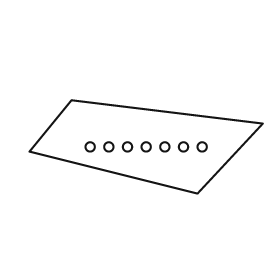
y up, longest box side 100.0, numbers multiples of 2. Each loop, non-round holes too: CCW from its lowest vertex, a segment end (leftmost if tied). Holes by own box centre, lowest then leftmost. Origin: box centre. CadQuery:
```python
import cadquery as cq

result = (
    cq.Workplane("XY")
    .moveTo(22.0, -20.0)
    .lineTo(50.0, 10.0)
    .lineTo(-32.0, 20.0)
    .lineTo(-50.0, -2.0)
    .close()
    .moveTo(-24.0, 0.0)
    .circle(2.0)
    .moveTo(-16.0, 0.0)
    .circle(2.0)
    .moveTo(-8.0, 0.0)
    .circle(2.0)
    .moveTo(0.0, 0.0)
    .circle(2.0)
    .moveTo(8.0, 0.0)
    .circle(2.0)
    .moveTo(16.0, 0.0)
    .circle(2.0)
    .moveTo(24.0, 0.0)
    .circle(2.0)
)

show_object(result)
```